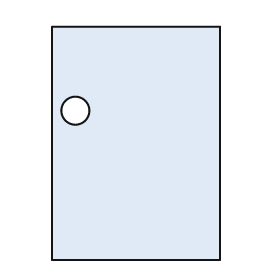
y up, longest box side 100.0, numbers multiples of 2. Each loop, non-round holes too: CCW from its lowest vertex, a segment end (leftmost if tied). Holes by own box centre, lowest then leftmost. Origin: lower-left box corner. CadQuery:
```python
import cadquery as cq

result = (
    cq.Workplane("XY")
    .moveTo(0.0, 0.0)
    .lineTo(72.0, 0.0)
    .lineTo(72.0, 100.0)
    .lineTo(0.0, 100.0)
    .close()
    .moveTo(10.0, 64.0)
    .circle(6.0)
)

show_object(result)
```